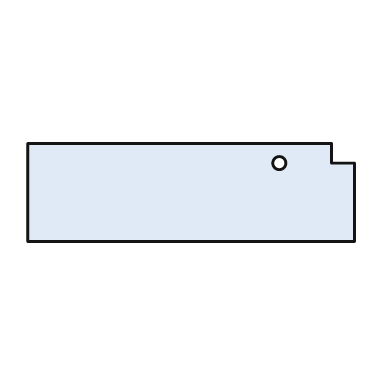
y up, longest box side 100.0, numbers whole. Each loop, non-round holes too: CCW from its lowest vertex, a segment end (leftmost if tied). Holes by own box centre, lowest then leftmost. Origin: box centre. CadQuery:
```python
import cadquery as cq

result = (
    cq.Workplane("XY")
    .moveTo(-50.0, -15.0)
    .lineTo(50.0, -15.0)
    .lineTo(50.0, 9.0)
    .lineTo(43.0, 9.0)
    .lineTo(43.0, 15.0)
    .lineTo(-50.0, 15.0)
    .close()
    .moveTo(27.0, 9.0)
    .circle(2.0)
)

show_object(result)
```